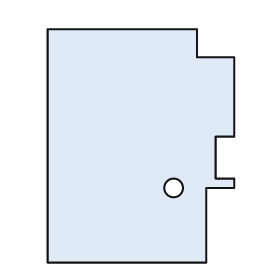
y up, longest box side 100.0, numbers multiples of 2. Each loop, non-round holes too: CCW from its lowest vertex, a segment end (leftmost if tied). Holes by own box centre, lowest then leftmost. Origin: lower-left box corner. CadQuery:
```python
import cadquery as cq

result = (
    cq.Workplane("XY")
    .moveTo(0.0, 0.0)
    .lineTo(68.0, 0.0)
    .lineTo(68.0, 32.0)
    .lineTo(80.0, 32.0)
    .lineTo(80.0, 36.0)
    .lineTo(72.0, 36.0)
    .lineTo(72.0, 54.0)
    .lineTo(80.0, 54.0)
    .lineTo(80.0, 88.0)
    .lineTo(64.0, 88.0)
    .lineTo(64.0, 100.0)
    .lineTo(0.0, 100.0)
    .close()
    .moveTo(54.0, 32.0)
    .circle(4.0)
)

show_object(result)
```